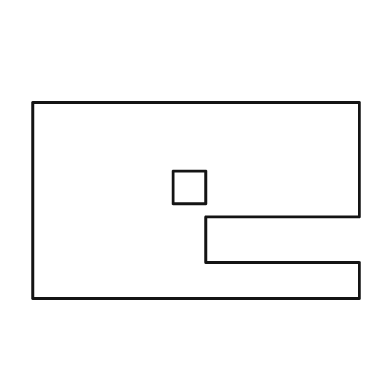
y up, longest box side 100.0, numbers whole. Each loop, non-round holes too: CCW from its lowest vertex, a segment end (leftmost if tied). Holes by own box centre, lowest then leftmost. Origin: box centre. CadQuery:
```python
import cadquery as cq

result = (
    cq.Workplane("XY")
    .moveTo(-50.0, -30.0)
    .lineTo(50.0, -30.0)
    .lineTo(50.0, -19.0)
    .lineTo(3.0, -19.0)
    .lineTo(3.0, -5.0)
    .lineTo(50.0, -5.0)
    .lineTo(50.0, 30.0)
    .lineTo(-50.0, 30.0)
    .close()
    .moveTo(-7.0, -1.0)
    .lineTo(3.0, -1.0)
    .lineTo(3.0, 9.0)
    .lineTo(-7.0, 9.0)
    .close()
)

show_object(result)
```